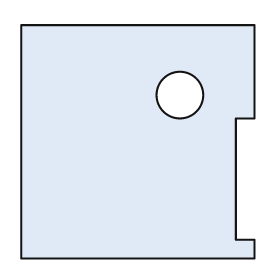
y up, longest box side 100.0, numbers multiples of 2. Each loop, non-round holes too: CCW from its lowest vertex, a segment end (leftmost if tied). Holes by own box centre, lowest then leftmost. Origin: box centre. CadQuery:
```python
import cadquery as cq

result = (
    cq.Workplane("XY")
    .moveTo(-50.0, -50.0)
    .lineTo(50.0, -50.0)
    .lineTo(50.0, -42.0)
    .lineTo(42.0, -42.0)
    .lineTo(42.0, 10.0)
    .lineTo(50.0, 10.0)
    .lineTo(50.0, 50.0)
    .lineTo(-50.0, 50.0)
    .close()
    .moveTo(18.0, 20.0)
    .circle(10.0)
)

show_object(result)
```